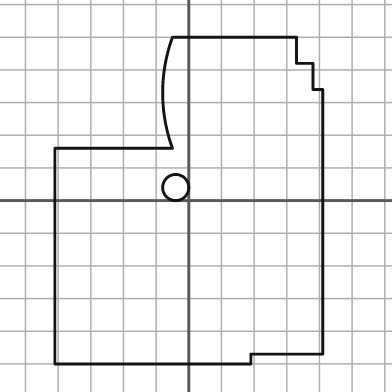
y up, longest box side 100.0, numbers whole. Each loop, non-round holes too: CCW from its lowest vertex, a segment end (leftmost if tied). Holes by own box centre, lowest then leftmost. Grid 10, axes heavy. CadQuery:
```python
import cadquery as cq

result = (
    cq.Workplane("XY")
    .moveTo(-41.0, -50.0)
    .lineTo(19.0, -50.0)
    .lineTo(19.0, -47.0)
    .lineTo(41.0, -47.0)
    .lineTo(41.0, 34.0)
    .lineTo(38.0, 34.0)
    .lineTo(38.0, 42.0)
    .lineTo(33.0, 42.0)
    .lineTo(33.0, 50.0)
    .lineTo(-5.0, 50.0)
    .threePointArc((-8.0, 33.0), (-5.0, 16.0))
    .lineTo(-41.0, 16.0)
    .close()
    .moveTo(-4.0, 4.0)
    .circle(4.0)
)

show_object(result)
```